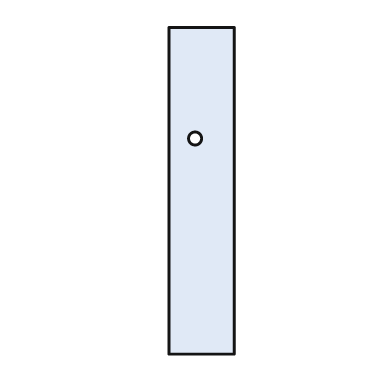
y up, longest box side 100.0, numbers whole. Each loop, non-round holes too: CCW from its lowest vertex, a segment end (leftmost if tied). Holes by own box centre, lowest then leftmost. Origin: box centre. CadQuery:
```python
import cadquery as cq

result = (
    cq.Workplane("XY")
    .moveTo(-10.0, -50.0)
    .lineTo(10.0, -50.0)
    .lineTo(10.0, 50.0)
    .lineTo(-10.0, 50.0)
    .close()
    .moveTo(-2.0, 16.0)
    .circle(2.0)
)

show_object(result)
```